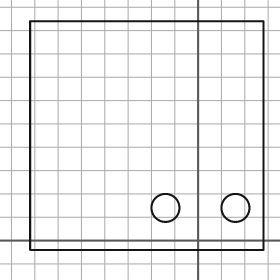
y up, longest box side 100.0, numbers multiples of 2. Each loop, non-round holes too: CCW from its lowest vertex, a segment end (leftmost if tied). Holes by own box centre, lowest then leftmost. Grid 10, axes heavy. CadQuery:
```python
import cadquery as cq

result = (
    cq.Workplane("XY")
    .moveTo(-72.0, -4.0)
    .lineTo(28.0, -4.0)
    .lineTo(28.0, 94.0)
    .lineTo(-72.0, 94.0)
    .close()
    .moveTo(-14.0, 14.0)
    .circle(6.0)
    .moveTo(16.0, 14.0)
    .circle(6.0)
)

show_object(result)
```